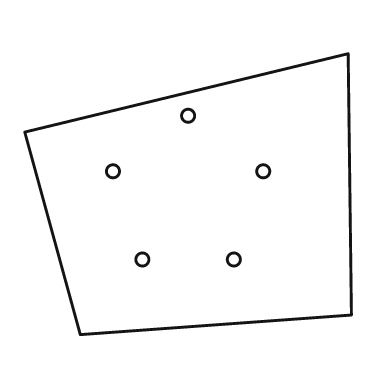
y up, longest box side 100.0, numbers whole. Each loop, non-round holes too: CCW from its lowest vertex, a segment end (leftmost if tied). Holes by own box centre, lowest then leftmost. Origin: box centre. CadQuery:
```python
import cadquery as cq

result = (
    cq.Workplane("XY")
    .moveTo(-33.0, -43.0)
    .lineTo(50.0, -37.0)
    .lineTo(49.0, 43.0)
    .lineTo(-50.0, 19.0)
    .close()
    .moveTo(-14.0, -20.0)
    .circle(2.0)
    .moveTo(14.0, -20.0)
    .circle(2.0)
    .moveTo(-23.0, 7.0)
    .circle(2.0)
    .moveTo(23.0, 7.0)
    .circle(2.0)
    .moveTo(0.0, 24.0)
    .circle(2.0)
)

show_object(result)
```